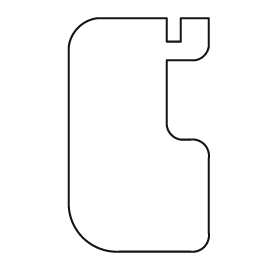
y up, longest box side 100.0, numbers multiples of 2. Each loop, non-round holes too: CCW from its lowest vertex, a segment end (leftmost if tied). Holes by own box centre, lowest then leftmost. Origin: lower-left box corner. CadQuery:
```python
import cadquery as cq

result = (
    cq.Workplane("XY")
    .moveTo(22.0, 0.0)
    .lineTo(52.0, 0.0)
    .threePointArc((58.0, 2.0), (60.0, 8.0))
    .lineTo(60.0, 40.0)
    .threePointArc((58.0, 46.0), (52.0, 48.0))
    .lineTo(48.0, 48.0)
    .threePointArc((44.0, 50.0), (42.0, 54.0))
    .lineTo(42.0, 82.0)
    .lineTo(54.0, 82.0)
    .threePointArc((58.0, 84.0), (60.0, 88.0))
    .lineTo(60.0, 100.0)
    .lineTo(48.0, 100.0)
    .lineTo(48.0, 90.0)
    .lineTo(42.0, 90.0)
    .lineTo(42.0, 100.0)
    .lineTo(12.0, 100.0)
    .threePointArc((4.0, 96.0), (0.0, 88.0))
    .lineTo(0.0, 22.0)
    .threePointArc((6.0, 6.0), (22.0, 0.0))
    .close()
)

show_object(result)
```